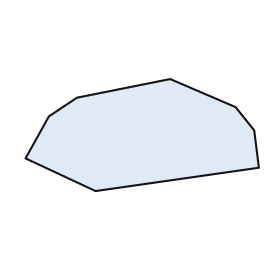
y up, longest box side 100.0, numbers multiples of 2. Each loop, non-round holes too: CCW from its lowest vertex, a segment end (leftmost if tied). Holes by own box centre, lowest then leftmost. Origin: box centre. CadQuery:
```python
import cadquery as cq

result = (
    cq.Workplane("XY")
    .moveTo(-20.0, -24.0)
    .lineTo(50.0, -14.0)
    .lineTo(48.0, 2.0)
    .lineTo(40.0, 12.0)
    .lineTo(12.0, 24.0)
    .lineTo(-28.0, 16.0)
    .lineTo(-40.0, 8.0)
    .lineTo(-50.0, -10.0)
    .close()
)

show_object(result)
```